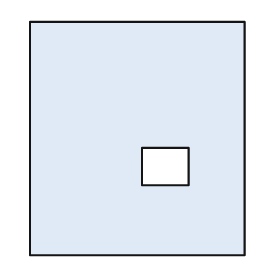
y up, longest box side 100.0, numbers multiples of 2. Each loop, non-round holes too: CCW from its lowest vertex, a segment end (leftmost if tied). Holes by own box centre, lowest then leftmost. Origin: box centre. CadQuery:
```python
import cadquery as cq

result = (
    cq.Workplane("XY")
    .moveTo(-46.0, -50.0)
    .lineTo(46.0, -50.0)
    .lineTo(46.0, 50.0)
    .lineTo(-46.0, 50.0)
    .close()
    .moveTo(2.0, -20.0)
    .lineTo(22.0, -20.0)
    .lineTo(22.0, -4.0)
    .lineTo(2.0, -4.0)
    .close()
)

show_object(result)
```